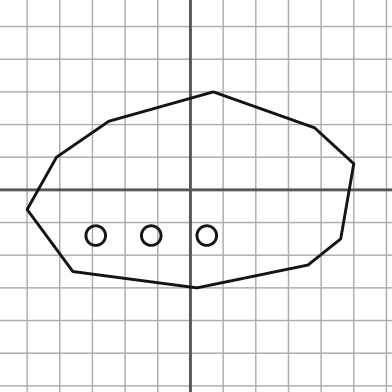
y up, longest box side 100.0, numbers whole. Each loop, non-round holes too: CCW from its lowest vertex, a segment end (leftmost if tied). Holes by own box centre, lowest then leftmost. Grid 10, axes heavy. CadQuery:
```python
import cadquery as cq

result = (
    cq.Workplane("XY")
    .moveTo(2.0, -30.0)
    .lineTo(36.0, -23.0)
    .lineTo(46.0, -15.0)
    .lineTo(50.0, 8.0)
    .lineTo(38.0, 19.0)
    .lineTo(7.0, 30.0)
    .lineTo(-25.0, 21.0)
    .lineTo(-41.0, 10.0)
    .lineTo(-50.0, -6.0)
    .lineTo(-36.0, -25.0)
    .close()
    .moveTo(-29.0, -14.0)
    .circle(3.0)
    .moveTo(-12.0, -14.0)
    .circle(3.0)
    .moveTo(5.0, -14.0)
    .circle(3.0)
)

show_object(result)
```